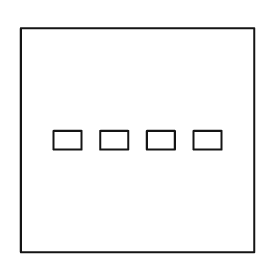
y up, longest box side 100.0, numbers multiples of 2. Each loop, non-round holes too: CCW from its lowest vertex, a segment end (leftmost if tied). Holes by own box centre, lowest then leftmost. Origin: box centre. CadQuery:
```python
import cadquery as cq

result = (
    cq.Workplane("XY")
    .moveTo(-50.0, -48.0)
    .lineTo(50.0, -48.0)
    .lineTo(50.0, 48.0)
    .lineTo(-50.0, 48.0)
    .close()
    .moveTo(-36.0, -4.0)
    .lineTo(-24.0, -4.0)
    .lineTo(-24.0, 4.0)
    .lineTo(-36.0, 4.0)
    .close()
    .moveTo(-16.0, -4.0)
    .lineTo(-4.0, -4.0)
    .lineTo(-4.0, 4.0)
    .lineTo(-16.0, 4.0)
    .close()
    .moveTo(4.0, -4.0)
    .lineTo(16.0, -4.0)
    .lineTo(16.0, 4.0)
    .lineTo(4.0, 4.0)
    .close()
    .moveTo(24.0, -4.0)
    .lineTo(36.0, -4.0)
    .lineTo(36.0, 4.0)
    .lineTo(24.0, 4.0)
    .close()
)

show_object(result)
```